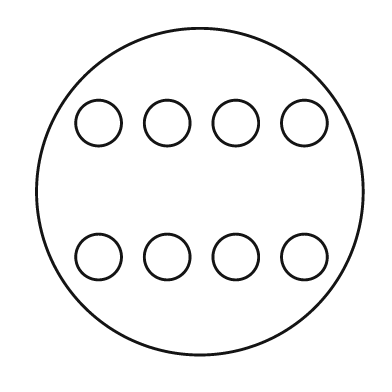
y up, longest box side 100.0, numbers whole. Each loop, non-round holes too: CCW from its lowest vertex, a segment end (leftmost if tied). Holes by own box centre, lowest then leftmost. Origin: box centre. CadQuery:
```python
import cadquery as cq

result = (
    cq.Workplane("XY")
    .moveTo(0.0, 0.0)
    .circle(50.0)
    .moveTo(-31.0, -20.0)
    .circle(7.0)
    .moveTo(-10.0, -20.0)
    .circle(7.0)
    .moveTo(11.0, -20.0)
    .circle(7.0)
    .moveTo(32.0, -20.0)
    .circle(7.0)
    .moveTo(-31.0, 21.0)
    .circle(7.0)
    .moveTo(-10.0, 21.0)
    .circle(7.0)
    .moveTo(11.0, 21.0)
    .circle(7.0)
    .moveTo(32.0, 21.0)
    .circle(7.0)
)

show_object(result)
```